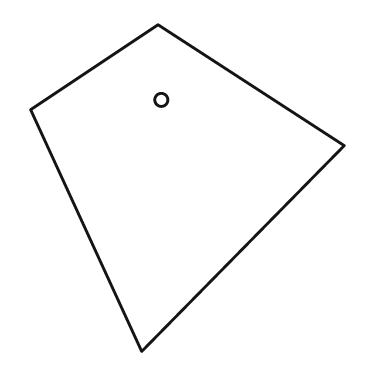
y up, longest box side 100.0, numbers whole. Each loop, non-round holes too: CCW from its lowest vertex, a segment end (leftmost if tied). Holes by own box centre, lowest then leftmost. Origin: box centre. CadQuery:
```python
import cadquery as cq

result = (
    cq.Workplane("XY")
    .moveTo(-14.0, -50.0)
    .lineTo(48.0, 13.0)
    .lineTo(-9.0, 50.0)
    .lineTo(-48.0, 24.0)
    .close()
    .moveTo(-8.0, 27.0)
    .circle(2.0)
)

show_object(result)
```